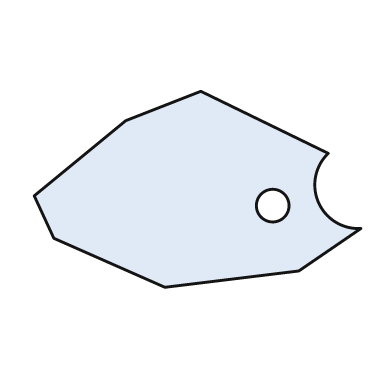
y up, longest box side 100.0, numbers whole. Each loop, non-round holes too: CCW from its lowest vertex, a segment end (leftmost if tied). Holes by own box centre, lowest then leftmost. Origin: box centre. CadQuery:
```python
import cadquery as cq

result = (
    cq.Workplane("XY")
    .moveTo(-10.0, -30.0)
    .lineTo(31.0, -25.0)
    .lineTo(50.0, -12.0)
    .threePointArc((37.0, -4.0), (40.0, 11.0))
    .lineTo(1.0, 30.0)
    .lineTo(-22.0, 21.0)
    .lineTo(-50.0, -2.0)
    .lineTo(-44.0, -15.0)
    .close()
    .moveTo(23.0, -5.0)
    .circle(5.0)
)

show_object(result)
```